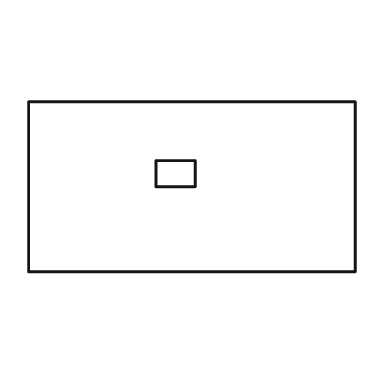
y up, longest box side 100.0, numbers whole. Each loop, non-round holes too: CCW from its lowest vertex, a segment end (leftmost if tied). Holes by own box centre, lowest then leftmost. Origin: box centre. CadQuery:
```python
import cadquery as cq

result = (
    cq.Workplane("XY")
    .moveTo(-50.0, -26.0)
    .lineTo(50.0, -26.0)
    .lineTo(50.0, 26.0)
    .lineTo(-50.0, 26.0)
    .close()
    .moveTo(-11.0, 0.0)
    .lineTo(1.0, 0.0)
    .lineTo(1.0, 8.0)
    .lineTo(-11.0, 8.0)
    .close()
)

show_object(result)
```